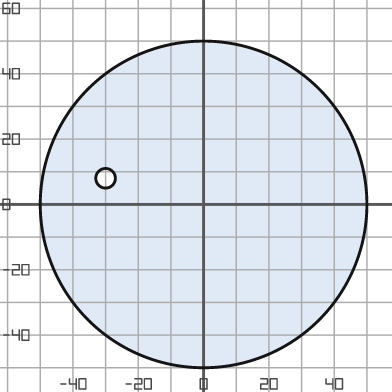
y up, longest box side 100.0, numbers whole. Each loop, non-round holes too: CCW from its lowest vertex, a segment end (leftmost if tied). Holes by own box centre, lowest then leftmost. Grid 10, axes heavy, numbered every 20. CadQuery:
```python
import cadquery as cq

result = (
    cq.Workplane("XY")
    .moveTo(0.0, 0.0)
    .circle(50.0)
    .moveTo(-30.0, 8.0)
    .circle(3.0)
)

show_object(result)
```